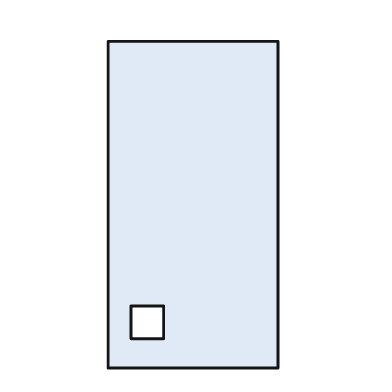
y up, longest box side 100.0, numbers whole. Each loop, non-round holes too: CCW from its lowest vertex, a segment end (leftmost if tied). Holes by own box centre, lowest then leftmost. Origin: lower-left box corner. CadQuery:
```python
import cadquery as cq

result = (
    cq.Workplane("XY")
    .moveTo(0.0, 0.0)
    .lineTo(52.0, 0.0)
    .lineTo(52.0, 100.0)
    .lineTo(0.0, 100.0)
    .close()
    .moveTo(7.0, 9.0)
    .lineTo(17.0, 9.0)
    .lineTo(17.0, 19.0)
    .lineTo(7.0, 19.0)
    .close()
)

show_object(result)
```